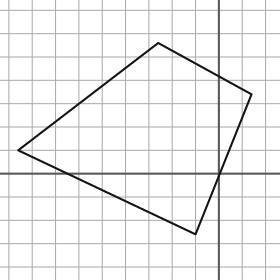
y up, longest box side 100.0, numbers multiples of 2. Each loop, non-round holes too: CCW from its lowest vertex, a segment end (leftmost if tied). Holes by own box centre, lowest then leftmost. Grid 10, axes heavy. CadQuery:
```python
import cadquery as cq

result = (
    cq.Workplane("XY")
    .moveTo(-10.0, -26.0)
    .lineTo(14.0, 34.0)
    .lineTo(-26.0, 56.0)
    .lineTo(-86.0, 10.0)
    .close()
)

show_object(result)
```